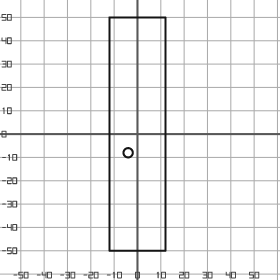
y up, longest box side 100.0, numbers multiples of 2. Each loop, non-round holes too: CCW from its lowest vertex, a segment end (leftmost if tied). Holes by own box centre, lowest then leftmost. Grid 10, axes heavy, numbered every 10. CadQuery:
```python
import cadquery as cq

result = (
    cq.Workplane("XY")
    .moveTo(-12.0, -50.0)
    .lineTo(12.0, -50.0)
    .lineTo(12.0, 50.0)
    .lineTo(-12.0, 50.0)
    .close()
    .moveTo(-4.0, -8.0)
    .circle(2.0)
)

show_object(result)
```